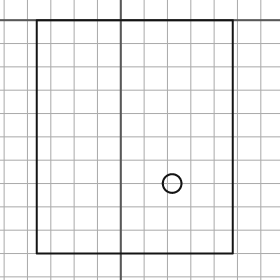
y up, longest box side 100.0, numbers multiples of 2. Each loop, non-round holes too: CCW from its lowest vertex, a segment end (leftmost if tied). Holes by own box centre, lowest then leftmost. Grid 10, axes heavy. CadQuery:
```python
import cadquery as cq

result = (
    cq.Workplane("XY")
    .moveTo(-36.0, -100.0)
    .lineTo(48.0, -100.0)
    .lineTo(48.0, 0.0)
    .lineTo(-36.0, 0.0)
    .close()
    .moveTo(22.0, -70.0)
    .circle(4.0)
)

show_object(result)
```